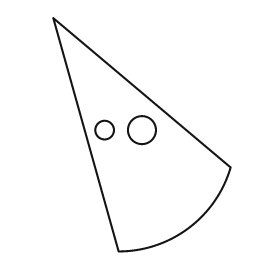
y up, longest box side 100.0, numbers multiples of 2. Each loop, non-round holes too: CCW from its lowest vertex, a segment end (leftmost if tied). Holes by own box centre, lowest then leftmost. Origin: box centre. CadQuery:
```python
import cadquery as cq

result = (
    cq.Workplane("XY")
    .moveTo(-10.0, -50.0)
    .threePointArc((20.0, -40.0), (38.0, -14.0))
    .lineTo(-38.0, 50.0)
    .close()
    .moveTo(-16.0, 2.0)
    .circle(4.0)
    .moveTo(0.0, 2.0)
    .circle(6.0)
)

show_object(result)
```